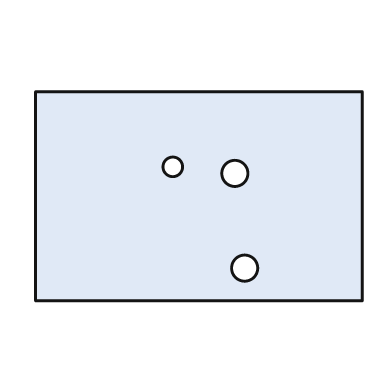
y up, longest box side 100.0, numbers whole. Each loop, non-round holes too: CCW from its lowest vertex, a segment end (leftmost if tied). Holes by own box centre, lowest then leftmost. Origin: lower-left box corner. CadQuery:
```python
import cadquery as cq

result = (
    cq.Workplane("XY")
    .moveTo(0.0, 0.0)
    .lineTo(100.0, 0.0)
    .lineTo(100.0, 64.0)
    .lineTo(0.0, 64.0)
    .close()
    .moveTo(64.0, 10.0)
    .circle(4.0)
    .moveTo(61.0, 39.0)
    .circle(4.0)
    .moveTo(42.0, 41.0)
    .circle(3.0)
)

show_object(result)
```